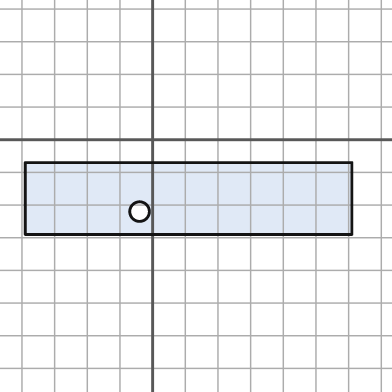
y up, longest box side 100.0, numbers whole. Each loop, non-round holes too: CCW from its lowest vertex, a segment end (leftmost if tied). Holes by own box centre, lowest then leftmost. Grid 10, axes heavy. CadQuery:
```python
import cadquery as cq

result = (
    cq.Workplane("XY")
    .moveTo(-39.0, -29.0)
    .lineTo(61.0, -29.0)
    .lineTo(61.0, -7.0)
    .lineTo(-39.0, -7.0)
    .close()
    .moveTo(-4.0, -22.0)
    .circle(3.0)
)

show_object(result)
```